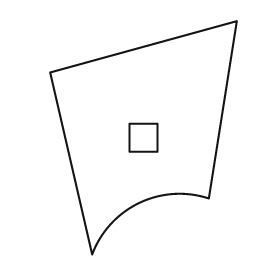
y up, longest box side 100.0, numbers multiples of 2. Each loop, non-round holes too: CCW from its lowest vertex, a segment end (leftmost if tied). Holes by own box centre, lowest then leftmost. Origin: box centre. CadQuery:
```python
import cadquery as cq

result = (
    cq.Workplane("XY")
    .moveTo(-22.0, -50.0)
    .threePointArc((-2.0, -28.0), (28.0, -26.0))
    .lineTo(40.0, 50.0)
    .lineTo(-40.0, 28.0)
    .close()
    .moveTo(-6.0, -6.0)
    .lineTo(6.0, -6.0)
    .lineTo(6.0, 6.0)
    .lineTo(-6.0, 6.0)
    .close()
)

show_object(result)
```